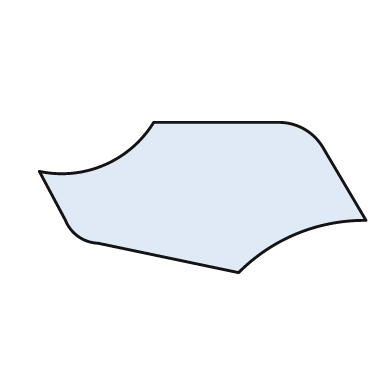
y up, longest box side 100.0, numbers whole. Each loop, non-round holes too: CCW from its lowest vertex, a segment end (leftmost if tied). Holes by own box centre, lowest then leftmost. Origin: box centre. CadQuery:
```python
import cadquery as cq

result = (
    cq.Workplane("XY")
    .moveTo(11.0, -23.0)
    .threePointArc((29.0, -11.0), (50.0, -7.0))
    .lineTo(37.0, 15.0)
    .threePointArc((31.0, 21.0), (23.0, 23.0))
    .lineTo(-15.0, 23.0)
    .threePointArc((-30.0, 10.0), (-50.0, 8.0))
    .lineTo(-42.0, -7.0)
    .threePointArc((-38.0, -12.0), (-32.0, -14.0))
    .close()
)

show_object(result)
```